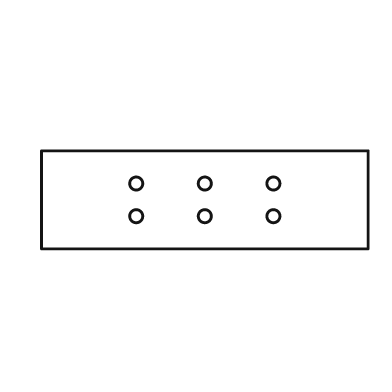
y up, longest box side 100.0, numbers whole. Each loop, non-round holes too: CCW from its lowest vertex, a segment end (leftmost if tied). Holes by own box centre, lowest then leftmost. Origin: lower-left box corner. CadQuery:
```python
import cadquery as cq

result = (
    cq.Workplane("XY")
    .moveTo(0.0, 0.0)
    .lineTo(100.0, 0.0)
    .lineTo(100.0, 30.0)
    .lineTo(0.0, 30.0)
    .close()
    .moveTo(29.0, 10.0)
    .circle(2.0)
    .moveTo(50.0, 10.0)
    .circle(2.0)
    .moveTo(71.0, 10.0)
    .circle(2.0)
    .moveTo(29.0, 20.0)
    .circle(2.0)
    .moveTo(50.0, 20.0)
    .circle(2.0)
    .moveTo(71.0, 20.0)
    .circle(2.0)
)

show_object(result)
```